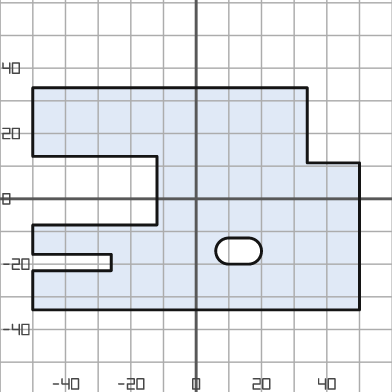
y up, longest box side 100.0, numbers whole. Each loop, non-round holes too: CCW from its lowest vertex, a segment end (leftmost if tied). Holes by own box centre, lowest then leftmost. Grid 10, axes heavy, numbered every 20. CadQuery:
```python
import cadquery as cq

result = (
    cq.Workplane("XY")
    .moveTo(-50.0, -34.0)
    .lineTo(50.0, -34.0)
    .lineTo(50.0, 11.0)
    .lineTo(34.0, 11.0)
    .lineTo(34.0, 34.0)
    .lineTo(-50.0, 34.0)
    .lineTo(-50.0, 13.0)
    .lineTo(-12.0, 13.0)
    .lineTo(-12.0, -8.0)
    .lineTo(-50.0, -8.0)
    .lineTo(-50.0, -17.0)
    .lineTo(-26.0, -17.0)
    .lineTo(-26.0, -22.0)
    .lineTo(-50.0, -22.0)
    .close()
    .moveTo(10.0, -20.0)
    .lineTo(16.0, -20.0)
    .threePointArc((20.0, -16.0), (16.0, -12.0))
    .lineTo(10.0, -12.0)
    .threePointArc((6.0, -16.0), (10.0, -20.0))
    .close()
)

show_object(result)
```